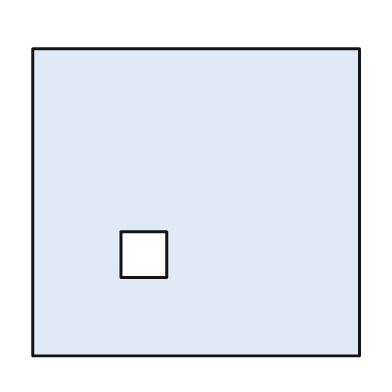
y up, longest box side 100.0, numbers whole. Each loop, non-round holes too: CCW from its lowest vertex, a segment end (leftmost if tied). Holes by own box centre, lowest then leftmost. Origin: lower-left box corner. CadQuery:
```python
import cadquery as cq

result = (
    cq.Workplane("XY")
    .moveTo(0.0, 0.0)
    .lineTo(100.0, 0.0)
    .lineTo(100.0, 94.0)
    .lineTo(0.0, 94.0)
    .close()
    .moveTo(27.0, 24.0)
    .lineTo(41.0, 24.0)
    .lineTo(41.0, 38.0)
    .lineTo(27.0, 38.0)
    .close()
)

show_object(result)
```